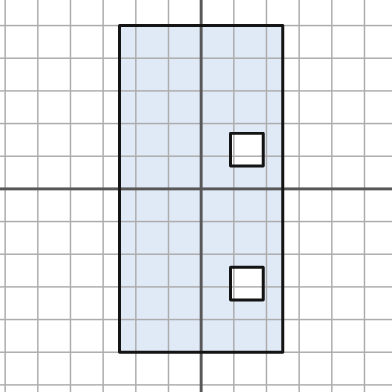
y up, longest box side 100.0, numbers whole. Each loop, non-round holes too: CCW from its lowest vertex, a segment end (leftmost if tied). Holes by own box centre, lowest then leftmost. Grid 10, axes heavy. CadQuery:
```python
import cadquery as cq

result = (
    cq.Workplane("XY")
    .moveTo(-25.0, -50.0)
    .lineTo(25.0, -50.0)
    .lineTo(25.0, 50.0)
    .lineTo(-25.0, 50.0)
    .close()
    .moveTo(9.0, -34.0)
    .lineTo(19.0, -34.0)
    .lineTo(19.0, -24.0)
    .lineTo(9.0, -24.0)
    .close()
    .moveTo(9.0, 7.0)
    .lineTo(19.0, 7.0)
    .lineTo(19.0, 17.0)
    .lineTo(9.0, 17.0)
    .close()
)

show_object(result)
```